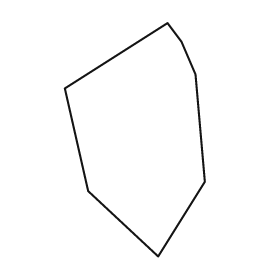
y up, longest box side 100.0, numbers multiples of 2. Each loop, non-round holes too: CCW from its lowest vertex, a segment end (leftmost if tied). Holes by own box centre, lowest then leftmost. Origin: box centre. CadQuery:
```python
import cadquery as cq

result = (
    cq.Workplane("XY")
    .moveTo(10.0, -50.0)
    .lineTo(30.0, -18.0)
    .lineTo(26.0, 28.0)
    .lineTo(20.0, 42.0)
    .lineTo(14.0, 50.0)
    .lineTo(-30.0, 22.0)
    .lineTo(-20.0, -22.0)
    .close()
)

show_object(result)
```